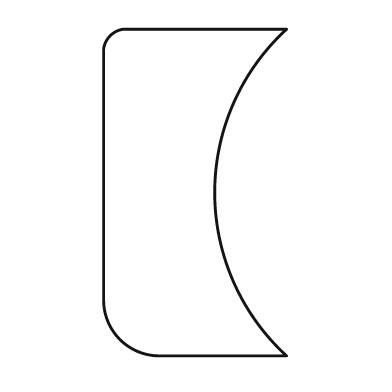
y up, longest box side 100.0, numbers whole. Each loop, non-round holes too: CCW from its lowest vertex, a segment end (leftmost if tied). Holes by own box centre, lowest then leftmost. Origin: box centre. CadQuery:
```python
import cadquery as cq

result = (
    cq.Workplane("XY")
    .moveTo(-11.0, -50.0)
    .lineTo(28.0, -50.0)
    .threePointArc((6.0, 0.0), (28.0, 50.0))
    .lineTo(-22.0, 50.0)
    .threePointArc((-26.0, 48.0), (-28.0, 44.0))
    .lineTo(-28.0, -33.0)
    .threePointArc((-23.0, -45.0), (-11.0, -50.0))
    .close()
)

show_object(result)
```